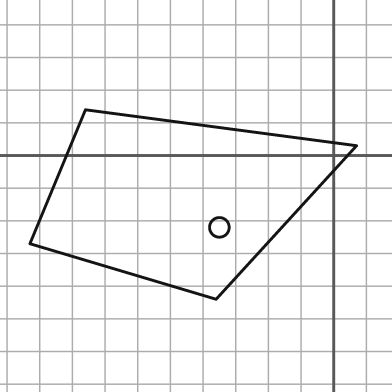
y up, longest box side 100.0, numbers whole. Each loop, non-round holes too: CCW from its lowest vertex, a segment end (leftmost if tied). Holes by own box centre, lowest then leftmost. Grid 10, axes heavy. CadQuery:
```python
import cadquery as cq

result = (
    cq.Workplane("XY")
    .moveTo(-36.0, -44.0)
    .lineTo(7.0, 3.0)
    .lineTo(-76.0, 14.0)
    .lineTo(-93.0, -27.0)
    .close()
    .moveTo(-35.0, -22.0)
    .circle(3.0)
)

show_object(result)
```